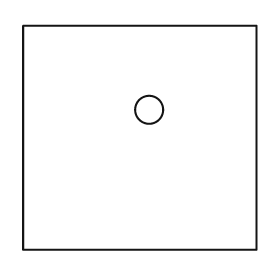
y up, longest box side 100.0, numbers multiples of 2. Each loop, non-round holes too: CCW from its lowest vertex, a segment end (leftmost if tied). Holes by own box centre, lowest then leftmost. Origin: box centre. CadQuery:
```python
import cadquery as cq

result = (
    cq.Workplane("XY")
    .moveTo(-50.0, -48.0)
    .lineTo(50.0, -48.0)
    .lineTo(50.0, 48.0)
    .lineTo(-50.0, 48.0)
    .close()
    .moveTo(4.0, 12.0)
    .circle(6.0)
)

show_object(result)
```